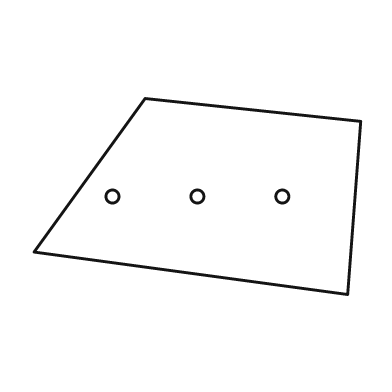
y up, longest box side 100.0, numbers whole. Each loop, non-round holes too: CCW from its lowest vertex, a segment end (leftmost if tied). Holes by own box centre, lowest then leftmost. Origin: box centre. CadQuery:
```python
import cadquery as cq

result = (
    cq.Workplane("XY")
    .moveTo(46.0, -30.0)
    .lineTo(50.0, 23.0)
    .lineTo(-16.0, 30.0)
    .lineTo(-50.0, -17.0)
    .close()
    .moveTo(-26.0, 0.0)
    .circle(2.0)
    .moveTo(0.0, 0.0)
    .circle(2.0)
    .moveTo(26.0, 0.0)
    .circle(2.0)
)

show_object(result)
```